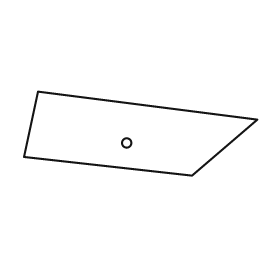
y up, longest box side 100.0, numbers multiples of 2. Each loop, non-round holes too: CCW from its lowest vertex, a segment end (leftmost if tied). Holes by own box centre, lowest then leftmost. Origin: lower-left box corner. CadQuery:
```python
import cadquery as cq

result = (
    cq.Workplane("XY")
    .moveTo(72.0, 0.0)
    .lineTo(100.0, 24.0)
    .lineTo(6.0, 36.0)
    .lineTo(0.0, 8.0)
    .close()
    .moveTo(44.0, 14.0)
    .circle(2.0)
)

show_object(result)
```